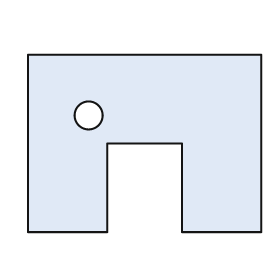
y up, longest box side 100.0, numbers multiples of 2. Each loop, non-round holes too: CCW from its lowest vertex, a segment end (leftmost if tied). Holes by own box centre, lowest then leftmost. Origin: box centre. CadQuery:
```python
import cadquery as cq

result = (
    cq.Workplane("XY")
    .moveTo(-50.0, -38.0)
    .lineTo(-16.0, -38.0)
    .lineTo(-16.0, 0.0)
    .lineTo(16.0, 0.0)
    .lineTo(16.0, -38.0)
    .lineTo(50.0, -38.0)
    .lineTo(50.0, 38.0)
    .lineTo(-50.0, 38.0)
    .close()
    .moveTo(-24.0, 12.0)
    .circle(6.0)
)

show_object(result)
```